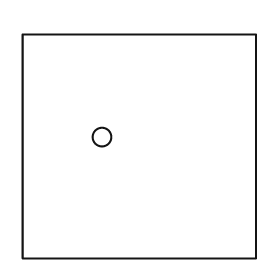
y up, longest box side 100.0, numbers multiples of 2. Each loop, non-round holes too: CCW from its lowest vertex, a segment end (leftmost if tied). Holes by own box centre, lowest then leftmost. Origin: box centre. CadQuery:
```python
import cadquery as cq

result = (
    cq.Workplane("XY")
    .moveTo(-50.0, -48.0)
    .lineTo(50.0, -48.0)
    .lineTo(50.0, 48.0)
    .lineTo(-50.0, 48.0)
    .close()
    .moveTo(-16.0, 4.0)
    .circle(4.0)
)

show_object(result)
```